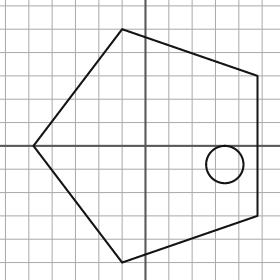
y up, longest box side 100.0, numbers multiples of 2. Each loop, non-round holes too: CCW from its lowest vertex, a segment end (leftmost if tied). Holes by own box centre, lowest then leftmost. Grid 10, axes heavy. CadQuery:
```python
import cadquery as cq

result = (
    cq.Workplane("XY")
    .moveTo(-10.0, -50.0)
    .lineTo(48.0, -30.0)
    .lineTo(48.0, 30.0)
    .lineTo(-10.0, 50.0)
    .lineTo(-48.0, 0.0)
    .close()
    .moveTo(34.0, -8.0)
    .circle(8.0)
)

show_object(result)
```